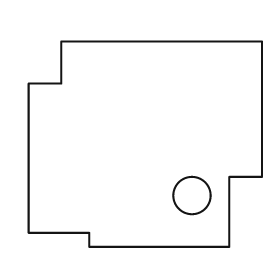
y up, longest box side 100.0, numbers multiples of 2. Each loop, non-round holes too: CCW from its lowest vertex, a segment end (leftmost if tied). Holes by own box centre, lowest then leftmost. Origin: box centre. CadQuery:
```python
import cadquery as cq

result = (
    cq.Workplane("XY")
    .moveTo(-24.0, -44.0)
    .lineTo(36.0, -44.0)
    .lineTo(36.0, -14.0)
    .lineTo(50.0, -14.0)
    .lineTo(50.0, 44.0)
    .lineTo(-36.0, 44.0)
    .lineTo(-36.0, 26.0)
    .lineTo(-50.0, 26.0)
    .lineTo(-50.0, -38.0)
    .lineTo(-24.0, -38.0)
    .close()
    .moveTo(20.0, -22.0)
    .circle(8.0)
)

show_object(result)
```